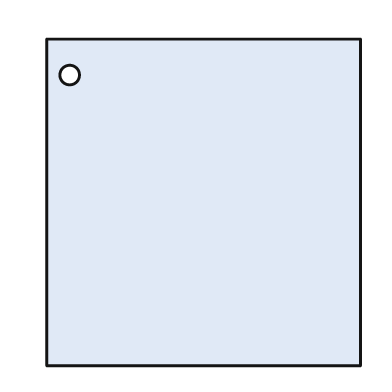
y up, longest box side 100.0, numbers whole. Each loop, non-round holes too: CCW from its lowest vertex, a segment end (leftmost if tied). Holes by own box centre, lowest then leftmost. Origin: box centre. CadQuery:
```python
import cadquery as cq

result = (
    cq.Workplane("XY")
    .moveTo(-48.0, -50.0)
    .lineTo(48.0, -50.0)
    .lineTo(48.0, 50.0)
    .lineTo(-48.0, 50.0)
    .close()
    .moveTo(-41.0, 39.0)
    .circle(3.0)
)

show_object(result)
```